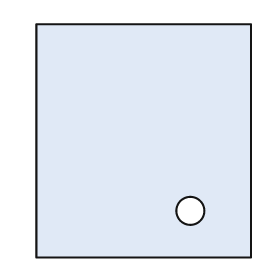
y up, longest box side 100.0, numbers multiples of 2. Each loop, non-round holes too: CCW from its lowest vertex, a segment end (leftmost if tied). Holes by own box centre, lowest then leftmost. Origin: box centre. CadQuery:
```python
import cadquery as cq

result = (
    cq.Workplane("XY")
    .moveTo(-46.0, -50.0)
    .lineTo(46.0, -50.0)
    .lineTo(46.0, 50.0)
    .lineTo(-46.0, 50.0)
    .close()
    .moveTo(20.0, -30.0)
    .circle(6.0)
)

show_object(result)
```